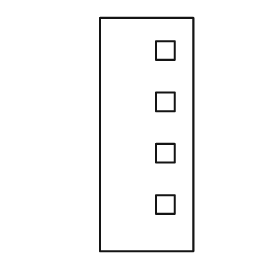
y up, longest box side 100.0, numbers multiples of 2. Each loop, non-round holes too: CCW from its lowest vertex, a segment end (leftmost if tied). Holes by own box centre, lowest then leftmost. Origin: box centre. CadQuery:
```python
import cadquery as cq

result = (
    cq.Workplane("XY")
    .moveTo(-20.0, -50.0)
    .lineTo(20.0, -50.0)
    .lineTo(20.0, 50.0)
    .lineTo(-20.0, 50.0)
    .close()
    .moveTo(4.0, -34.0)
    .lineTo(12.0, -34.0)
    .lineTo(12.0, -26.0)
    .lineTo(4.0, -26.0)
    .close()
    .moveTo(4.0, -12.0)
    .lineTo(12.0, -12.0)
    .lineTo(12.0, -4.0)
    .lineTo(4.0, -4.0)
    .close()
    .moveTo(4.0, 10.0)
    .lineTo(12.0, 10.0)
    .lineTo(12.0, 18.0)
    .lineTo(4.0, 18.0)
    .close()
    .moveTo(4.0, 32.0)
    .lineTo(12.0, 32.0)
    .lineTo(12.0, 40.0)
    .lineTo(4.0, 40.0)
    .close()
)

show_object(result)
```